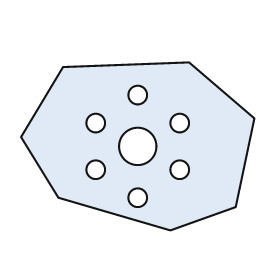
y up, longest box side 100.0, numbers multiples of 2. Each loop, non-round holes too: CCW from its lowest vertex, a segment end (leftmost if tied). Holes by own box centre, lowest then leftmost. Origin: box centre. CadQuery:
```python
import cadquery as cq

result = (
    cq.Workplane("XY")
    .moveTo(14.0, -36.0)
    .lineTo(42.0, -26.0)
    .lineTo(50.0, 12.0)
    .lineTo(22.0, 36.0)
    .lineTo(-32.0, 34.0)
    .lineTo(-50.0, 4.0)
    .lineTo(-34.0, -22.0)
    .close()
    .moveTo(0.0, -22.0)
    .circle(4.0)
    .moveTo(-18.0, -10.0)
    .circle(4.0)
    .moveTo(18.0, -10.0)
    .circle(4.0)
    .moveTo(0.0, 0.0)
    .circle(8.0)
    .moveTo(-18.0, 10.0)
    .circle(4.0)
    .moveTo(18.0, 10.0)
    .circle(4.0)
    .moveTo(0.0, 22.0)
    .circle(4.0)
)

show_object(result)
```